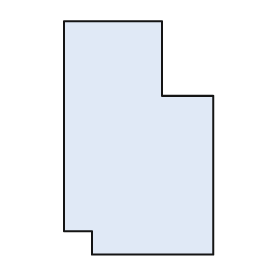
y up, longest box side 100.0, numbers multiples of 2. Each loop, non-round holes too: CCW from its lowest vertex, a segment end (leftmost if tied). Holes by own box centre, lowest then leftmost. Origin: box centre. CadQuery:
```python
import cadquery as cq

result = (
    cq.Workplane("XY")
    .moveTo(-20.0, -50.0)
    .lineTo(32.0, -50.0)
    .lineTo(32.0, 18.0)
    .lineTo(10.0, 18.0)
    .lineTo(10.0, 50.0)
    .lineTo(-32.0, 50.0)
    .lineTo(-32.0, -40.0)
    .lineTo(-20.0, -40.0)
    .close()
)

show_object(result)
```